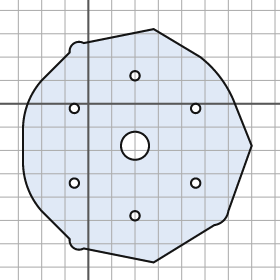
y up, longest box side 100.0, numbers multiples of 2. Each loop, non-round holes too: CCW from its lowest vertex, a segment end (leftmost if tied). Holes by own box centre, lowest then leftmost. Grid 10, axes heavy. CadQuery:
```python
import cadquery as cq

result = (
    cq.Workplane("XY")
    .moveTo(28.0, -68.0)
    .lineTo(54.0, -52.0)
    .threePointArc((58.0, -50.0), (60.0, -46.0))
    .lineTo(70.0, -18.0)
    .lineTo(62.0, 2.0)
    .threePointArc((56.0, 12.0), (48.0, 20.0))
    .lineTo(28.0, 32.0)
    .lineTo(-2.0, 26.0)
    .threePointArc((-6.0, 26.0), (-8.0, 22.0))
    .lineTo(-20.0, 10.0)
    .threePointArc((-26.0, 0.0), (-28.0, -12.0))
    .lineTo(-28.0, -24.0)
    .threePointArc((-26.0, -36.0), (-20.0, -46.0))
    .lineTo(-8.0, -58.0)
    .threePointArc((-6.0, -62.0), (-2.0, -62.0))
    .close()
    .moveTo(20.0, -48.0)
    .circle(2.0)
    .moveTo(-6.0, -34.0)
    .circle(2.0)
    .moveTo(46.0, -34.0)
    .circle(2.0)
    .moveTo(20.0, -18.0)
    .circle(6.0)
    .moveTo(-6.0, -2.0)
    .circle(2.0)
    .moveTo(46.0, -2.0)
    .circle(2.0)
    .moveTo(20.0, 12.0)
    .circle(2.0)
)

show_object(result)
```